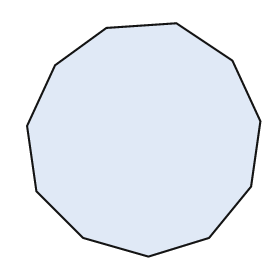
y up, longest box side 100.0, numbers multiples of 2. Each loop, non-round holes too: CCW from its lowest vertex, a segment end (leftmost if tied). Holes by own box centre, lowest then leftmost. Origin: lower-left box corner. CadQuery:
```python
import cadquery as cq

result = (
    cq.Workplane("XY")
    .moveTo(52.0, 0.0)
    .lineTo(78.0, 8.0)
    .lineTo(96.0, 30.0)
    .lineTo(100.0, 58.0)
    .lineTo(88.0, 84.0)
    .lineTo(64.0, 100.0)
    .lineTo(34.0, 98.0)
    .lineTo(12.0, 82.0)
    .lineTo(0.0, 56.0)
    .lineTo(4.0, 28.0)
    .lineTo(24.0, 8.0)
    .close()
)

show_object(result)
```